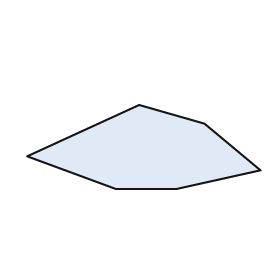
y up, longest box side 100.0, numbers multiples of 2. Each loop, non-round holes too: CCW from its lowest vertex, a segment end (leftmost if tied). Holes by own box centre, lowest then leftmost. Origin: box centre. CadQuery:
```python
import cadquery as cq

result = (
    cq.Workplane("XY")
    .moveTo(-12.0, -18.0)
    .lineTo(14.0, -18.0)
    .lineTo(50.0, -10.0)
    .lineTo(26.0, 10.0)
    .lineTo(-2.0, 18.0)
    .lineTo(-50.0, -4.0)
    .close()
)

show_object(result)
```